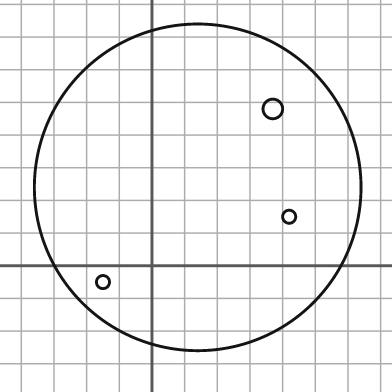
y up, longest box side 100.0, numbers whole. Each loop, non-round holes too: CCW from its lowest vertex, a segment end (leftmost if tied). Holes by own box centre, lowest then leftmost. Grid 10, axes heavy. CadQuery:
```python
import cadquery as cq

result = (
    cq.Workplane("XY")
    .moveTo(14.0, 24.0)
    .circle(50.0)
    .moveTo(-15.0, -5.0)
    .circle(2.0)
    .moveTo(42.0, 15.0)
    .circle(2.0)
    .moveTo(37.0, 48.0)
    .circle(3.0)
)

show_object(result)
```